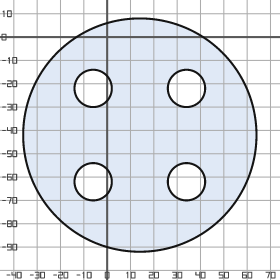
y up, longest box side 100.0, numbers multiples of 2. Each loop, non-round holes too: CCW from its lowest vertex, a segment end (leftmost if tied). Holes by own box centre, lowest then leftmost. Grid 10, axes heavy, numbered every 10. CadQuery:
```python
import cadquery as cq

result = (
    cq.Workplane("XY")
    .moveTo(14.0, -42.0)
    .circle(50.0)
    .moveTo(-6.0, -62.0)
    .circle(8.0)
    .moveTo(34.0, -62.0)
    .circle(8.0)
    .moveTo(-6.0, -22.0)
    .circle(8.0)
    .moveTo(34.0, -22.0)
    .circle(8.0)
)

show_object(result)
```